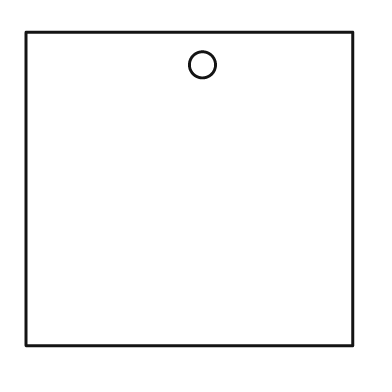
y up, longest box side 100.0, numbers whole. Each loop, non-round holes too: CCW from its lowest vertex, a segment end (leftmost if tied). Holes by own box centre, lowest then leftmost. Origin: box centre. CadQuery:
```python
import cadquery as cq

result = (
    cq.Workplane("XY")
    .moveTo(-50.0, -48.0)
    .lineTo(50.0, -48.0)
    .lineTo(50.0, 48.0)
    .lineTo(-50.0, 48.0)
    .close()
    .moveTo(4.0, 38.0)
    .circle(4.0)
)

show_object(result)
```